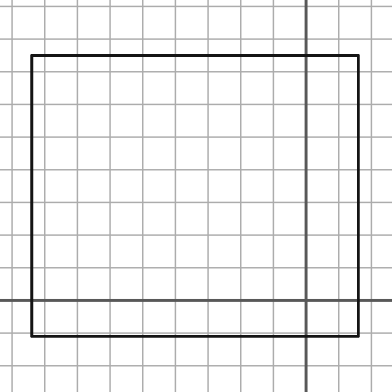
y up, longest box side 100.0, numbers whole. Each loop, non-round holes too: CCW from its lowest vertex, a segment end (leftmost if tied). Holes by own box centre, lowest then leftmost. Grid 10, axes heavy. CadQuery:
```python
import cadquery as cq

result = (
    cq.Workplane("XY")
    .moveTo(-84.0, -11.0)
    .lineTo(16.0, -11.0)
    .lineTo(16.0, 75.0)
    .lineTo(-84.0, 75.0)
    .close()
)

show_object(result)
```